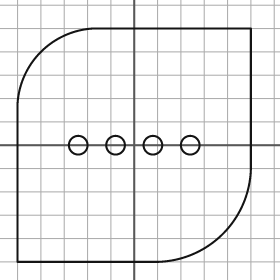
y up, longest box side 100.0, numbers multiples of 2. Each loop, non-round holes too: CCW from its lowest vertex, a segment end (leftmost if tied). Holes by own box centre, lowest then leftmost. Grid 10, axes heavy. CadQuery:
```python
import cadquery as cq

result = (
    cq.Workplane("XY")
    .moveTo(-50.0, -50.0)
    .lineTo(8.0, -50.0)
    .threePointArc((38.0, -38.0), (50.0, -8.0))
    .lineTo(50.0, 50.0)
    .lineTo(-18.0, 50.0)
    .threePointArc((-40.0, 40.0), (-50.0, 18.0))
    .close()
    .moveTo(-24.0, 0.0)
    .circle(4.0)
    .moveTo(-8.0, 0.0)
    .circle(4.0)
    .moveTo(8.0, 0.0)
    .circle(4.0)
    .moveTo(24.0, 0.0)
    .circle(4.0)
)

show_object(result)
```